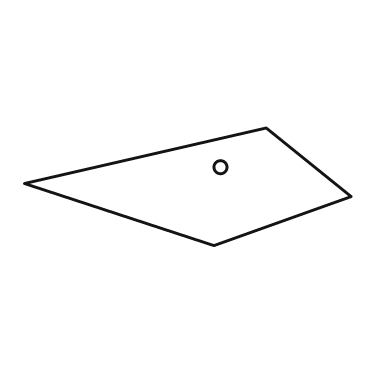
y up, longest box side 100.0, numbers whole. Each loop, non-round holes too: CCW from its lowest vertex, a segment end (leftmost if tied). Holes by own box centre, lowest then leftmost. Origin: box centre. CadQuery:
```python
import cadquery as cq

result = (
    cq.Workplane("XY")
    .moveTo(8.0, -18.0)
    .lineTo(50.0, -3.0)
    .lineTo(24.0, 18.0)
    .lineTo(-50.0, 1.0)
    .close()
    .moveTo(10.0, 6.0)
    .circle(2.0)
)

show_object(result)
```